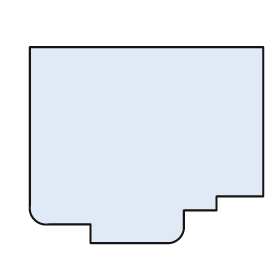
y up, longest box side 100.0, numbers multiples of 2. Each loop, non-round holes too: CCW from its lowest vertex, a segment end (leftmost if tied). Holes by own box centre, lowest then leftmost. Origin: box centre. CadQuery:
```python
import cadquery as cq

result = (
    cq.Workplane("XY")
    .moveTo(-24.0, -42.0)
    .lineTo(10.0, -42.0)
    .threePointArc((14.0, -40.0), (16.0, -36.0))
    .lineTo(16.0, -28.0)
    .lineTo(30.0, -28.0)
    .lineTo(30.0, -22.0)
    .lineTo(50.0, -22.0)
    .lineTo(50.0, 42.0)
    .lineTo(-50.0, 42.0)
    .lineTo(-50.0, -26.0)
    .threePointArc((-48.0, -32.0), (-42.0, -34.0))
    .lineTo(-24.0, -34.0)
    .close()
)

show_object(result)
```